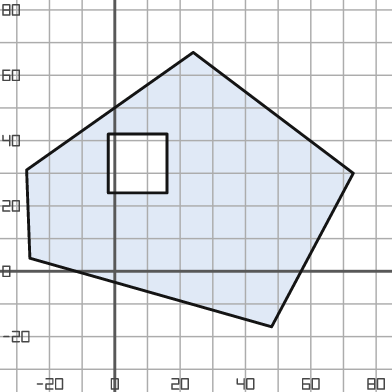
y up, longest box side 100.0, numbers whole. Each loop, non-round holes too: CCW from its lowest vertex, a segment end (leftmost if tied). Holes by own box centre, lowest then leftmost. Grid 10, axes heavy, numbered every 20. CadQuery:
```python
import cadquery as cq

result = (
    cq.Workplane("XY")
    .moveTo(48.0, -17.0)
    .lineTo(73.0, 30.0)
    .lineTo(24.0, 67.0)
    .lineTo(-27.0, 31.0)
    .lineTo(-26.0, 4.0)
    .close()
    .moveTo(-2.0, 24.0)
    .lineTo(16.0, 24.0)
    .lineTo(16.0, 42.0)
    .lineTo(-2.0, 42.0)
    .close()
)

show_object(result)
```